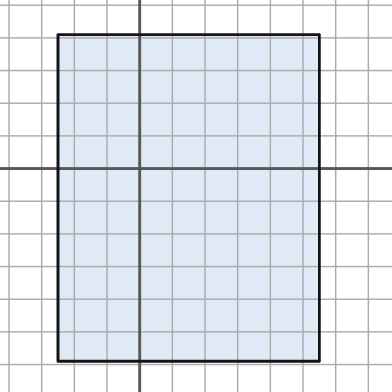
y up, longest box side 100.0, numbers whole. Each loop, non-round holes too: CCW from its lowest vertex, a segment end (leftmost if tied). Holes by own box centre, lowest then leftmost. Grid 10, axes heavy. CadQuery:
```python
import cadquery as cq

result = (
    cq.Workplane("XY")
    .moveTo(-25.0, -59.0)
    .lineTo(55.0, -59.0)
    .lineTo(55.0, 41.0)
    .lineTo(-25.0, 41.0)
    .close()
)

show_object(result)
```